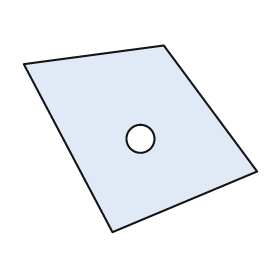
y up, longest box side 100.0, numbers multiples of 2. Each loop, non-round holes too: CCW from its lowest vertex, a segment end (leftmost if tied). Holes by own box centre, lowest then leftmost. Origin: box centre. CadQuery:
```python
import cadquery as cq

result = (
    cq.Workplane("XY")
    .moveTo(-12.0, -40.0)
    .lineTo(50.0, -14.0)
    .lineTo(10.0, 40.0)
    .lineTo(-50.0, 32.0)
    .close()
    .moveTo(0.0, 0.0)
    .circle(6.0)
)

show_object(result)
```